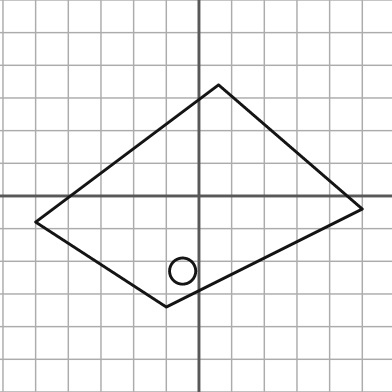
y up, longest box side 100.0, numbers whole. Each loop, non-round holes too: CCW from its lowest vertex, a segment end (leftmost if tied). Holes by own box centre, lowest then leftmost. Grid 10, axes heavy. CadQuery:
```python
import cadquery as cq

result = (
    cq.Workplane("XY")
    .moveTo(-10.0, -34.0)
    .lineTo(50.0, -4.0)
    .lineTo(6.0, 34.0)
    .lineTo(-50.0, -8.0)
    .close()
    .moveTo(-5.0, -23.0)
    .circle(4.0)
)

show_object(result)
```